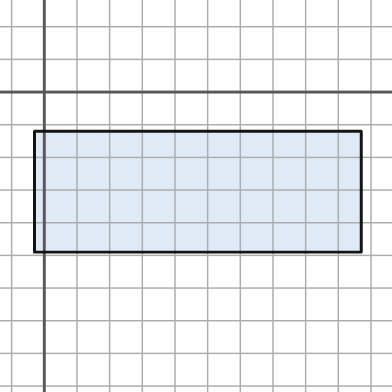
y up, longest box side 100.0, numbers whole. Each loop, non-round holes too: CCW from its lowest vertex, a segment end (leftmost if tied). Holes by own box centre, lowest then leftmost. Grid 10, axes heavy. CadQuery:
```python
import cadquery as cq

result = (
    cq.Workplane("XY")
    .moveTo(-3.0, -49.0)
    .lineTo(97.0, -49.0)
    .lineTo(97.0, -12.0)
    .lineTo(-3.0, -12.0)
    .close()
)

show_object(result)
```